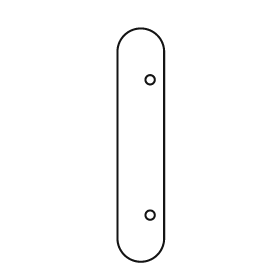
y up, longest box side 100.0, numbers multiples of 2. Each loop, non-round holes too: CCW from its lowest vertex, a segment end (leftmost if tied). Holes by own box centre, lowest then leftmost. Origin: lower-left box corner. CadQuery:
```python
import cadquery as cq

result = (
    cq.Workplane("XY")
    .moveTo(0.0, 10.0)
    .threePointArc((10.0, 0.0), (20.0, 10.0))
    .lineTo(20.0, 90.0)
    .threePointArc((10.0, 100.0), (0.0, 90.0))
    .close()
    .moveTo(14.0, 20.0)
    .circle(2.0)
    .moveTo(14.0, 78.0)
    .circle(2.0)
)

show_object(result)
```